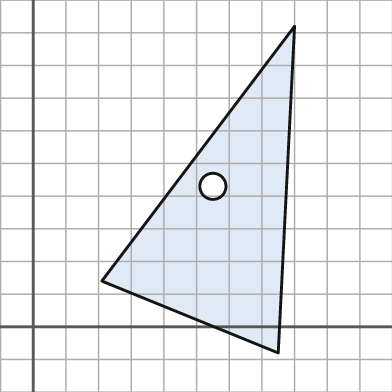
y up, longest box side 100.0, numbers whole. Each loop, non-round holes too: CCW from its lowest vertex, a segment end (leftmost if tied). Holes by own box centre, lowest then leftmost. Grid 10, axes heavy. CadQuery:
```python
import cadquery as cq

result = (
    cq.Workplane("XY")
    .moveTo(75.0, -8.0)
    .lineTo(80.0, 92.0)
    .lineTo(21.0, 14.0)
    .close()
    .moveTo(55.0, 43.0)
    .circle(4.0)
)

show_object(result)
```